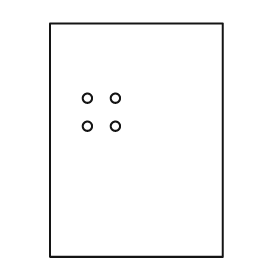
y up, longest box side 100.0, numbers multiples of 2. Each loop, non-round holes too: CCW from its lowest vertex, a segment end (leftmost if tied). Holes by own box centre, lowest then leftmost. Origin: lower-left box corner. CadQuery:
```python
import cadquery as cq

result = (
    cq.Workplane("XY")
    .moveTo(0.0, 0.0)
    .lineTo(74.0, 0.0)
    .lineTo(74.0, 100.0)
    .lineTo(0.0, 100.0)
    .close()
    .moveTo(16.0, 56.0)
    .circle(2.0)
    .moveTo(28.0, 56.0)
    .circle(2.0)
    .moveTo(16.0, 68.0)
    .circle(2.0)
    .moveTo(28.0, 68.0)
    .circle(2.0)
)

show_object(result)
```